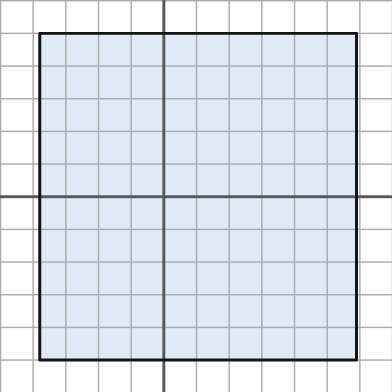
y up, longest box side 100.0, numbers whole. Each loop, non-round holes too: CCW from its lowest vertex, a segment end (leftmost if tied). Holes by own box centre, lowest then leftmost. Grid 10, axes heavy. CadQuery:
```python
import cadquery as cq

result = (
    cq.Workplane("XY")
    .moveTo(-38.0, -50.0)
    .lineTo(59.0, -50.0)
    .lineTo(59.0, 50.0)
    .lineTo(-38.0, 50.0)
    .close()
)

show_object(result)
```